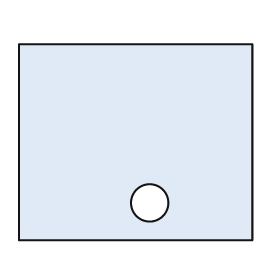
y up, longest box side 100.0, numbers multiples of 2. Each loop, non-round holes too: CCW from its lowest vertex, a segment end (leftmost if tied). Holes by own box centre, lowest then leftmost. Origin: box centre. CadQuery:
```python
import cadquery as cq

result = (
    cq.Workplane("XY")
    .moveTo(-50.0, -42.0)
    .lineTo(50.0, -42.0)
    .lineTo(50.0, 42.0)
    .lineTo(-50.0, 42.0)
    .close()
    .moveTo(6.0, -26.0)
    .circle(8.0)
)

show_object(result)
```